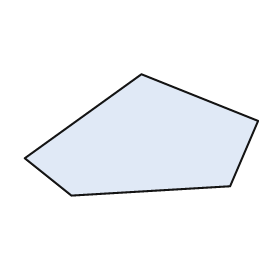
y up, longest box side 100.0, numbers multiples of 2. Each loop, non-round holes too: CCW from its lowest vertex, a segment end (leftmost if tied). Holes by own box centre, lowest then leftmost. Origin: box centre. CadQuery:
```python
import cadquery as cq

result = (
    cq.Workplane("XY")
    .moveTo(-30.0, -26.0)
    .lineTo(38.0, -22.0)
    .lineTo(50.0, 6.0)
    .lineTo(0.0, 26.0)
    .lineTo(-50.0, -10.0)
    .close()
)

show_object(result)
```